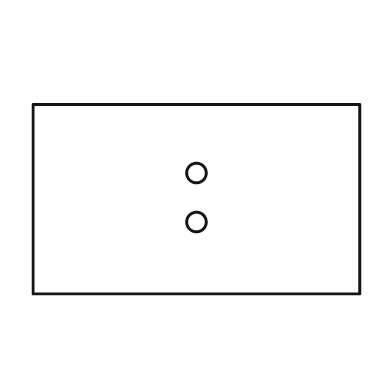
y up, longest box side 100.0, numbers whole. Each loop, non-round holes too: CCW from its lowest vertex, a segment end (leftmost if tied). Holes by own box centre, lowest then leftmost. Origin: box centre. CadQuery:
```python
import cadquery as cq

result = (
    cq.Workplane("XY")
    .moveTo(-50.0, -29.0)
    .lineTo(50.0, -29.0)
    .lineTo(50.0, 29.0)
    .lineTo(-50.0, 29.0)
    .close()
    .moveTo(0.0, -7.0)
    .circle(3.0)
    .moveTo(0.0, 8.0)
    .circle(3.0)
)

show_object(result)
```